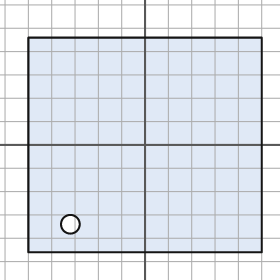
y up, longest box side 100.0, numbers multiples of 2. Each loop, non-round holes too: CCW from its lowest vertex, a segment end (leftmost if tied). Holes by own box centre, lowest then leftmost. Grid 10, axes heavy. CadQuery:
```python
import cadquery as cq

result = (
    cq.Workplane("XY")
    .moveTo(-50.0, -46.0)
    .lineTo(50.0, -46.0)
    .lineTo(50.0, 46.0)
    .lineTo(-50.0, 46.0)
    .close()
    .moveTo(-32.0, -34.0)
    .circle(4.0)
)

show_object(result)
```